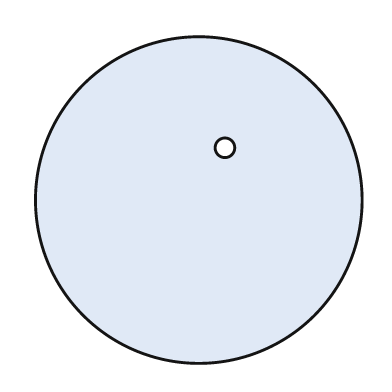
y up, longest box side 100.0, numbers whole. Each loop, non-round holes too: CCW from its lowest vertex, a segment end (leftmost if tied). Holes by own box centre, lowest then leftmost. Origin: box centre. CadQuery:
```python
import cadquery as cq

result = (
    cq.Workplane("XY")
    .moveTo(0.0, 0.0)
    .circle(50.0)
    .moveTo(8.0, 16.0)
    .circle(3.0)
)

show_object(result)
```